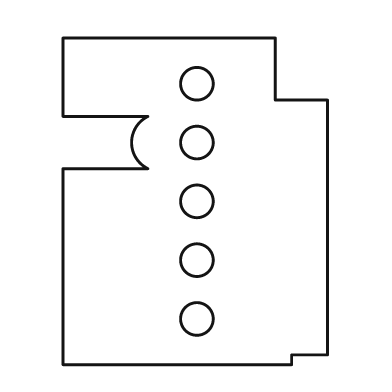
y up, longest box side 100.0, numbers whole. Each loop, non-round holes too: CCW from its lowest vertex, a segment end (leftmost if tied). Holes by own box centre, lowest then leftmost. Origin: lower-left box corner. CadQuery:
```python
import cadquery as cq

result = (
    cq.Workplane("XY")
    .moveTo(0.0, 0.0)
    .lineTo(70.0, 0.0)
    .lineTo(70.0, 3.0)
    .lineTo(81.0, 3.0)
    .lineTo(81.0, 81.0)
    .lineTo(65.0, 81.0)
    .lineTo(65.0, 100.0)
    .lineTo(0.0, 100.0)
    .lineTo(0.0, 76.0)
    .lineTo(26.0, 76.0)
    .threePointArc((21.0, 68.0), (26.0, 60.0))
    .lineTo(0.0, 60.0)
    .close()
    .moveTo(41.0, 14.0)
    .circle(5.0)
    .moveTo(41.0, 32.0)
    .circle(5.0)
    .moveTo(41.0, 50.0)
    .circle(5.0)
    .moveTo(41.0, 68.0)
    .circle(5.0)
    .moveTo(41.0, 86.0)
    .circle(5.0)
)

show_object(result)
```